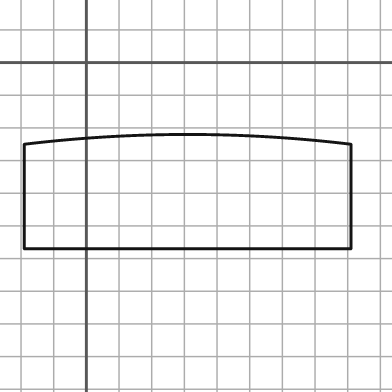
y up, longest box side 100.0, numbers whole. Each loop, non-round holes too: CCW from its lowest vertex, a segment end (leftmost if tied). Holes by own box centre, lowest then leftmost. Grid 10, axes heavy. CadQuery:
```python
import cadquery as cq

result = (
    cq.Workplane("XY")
    .moveTo(-19.0, -57.0)
    .lineTo(81.0, -57.0)
    .lineTo(81.0, -25.0)
    .threePointArc((31.0, -22.0), (-19.0, -25.0))
    .close()
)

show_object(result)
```